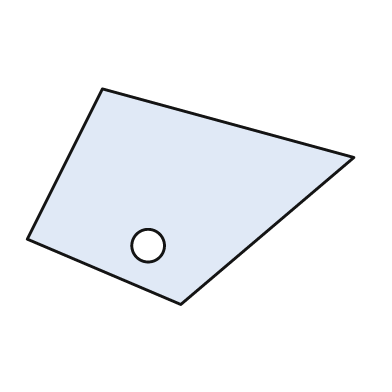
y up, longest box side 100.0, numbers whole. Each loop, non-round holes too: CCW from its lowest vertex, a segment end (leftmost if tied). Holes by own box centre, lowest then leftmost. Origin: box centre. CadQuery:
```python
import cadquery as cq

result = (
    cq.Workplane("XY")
    .moveTo(-3.0, -33.0)
    .lineTo(50.0, 12.0)
    .lineTo(-27.0, 33.0)
    .lineTo(-50.0, -13.0)
    .close()
    .moveTo(-13.0, -15.0)
    .circle(5.0)
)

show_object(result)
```